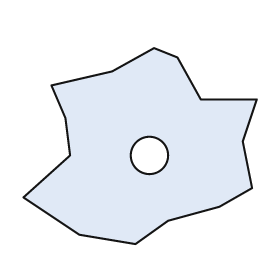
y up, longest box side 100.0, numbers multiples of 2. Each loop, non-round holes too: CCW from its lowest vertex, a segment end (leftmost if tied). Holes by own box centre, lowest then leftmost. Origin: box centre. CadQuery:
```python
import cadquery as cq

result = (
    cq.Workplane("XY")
    .moveTo(-2.0, -42.0)
    .lineTo(12.0, -32.0)
    .lineTo(34.0, -26.0)
    .lineTo(48.0, -18.0)
    .lineTo(44.0, 2.0)
    .lineTo(50.0, 20.0)
    .lineTo(26.0, 20.0)
    .lineTo(16.0, 38.0)
    .lineTo(6.0, 42.0)
    .lineTo(-12.0, 32.0)
    .lineTo(-38.0, 26.0)
    .lineTo(-32.0, 12.0)
    .lineTo(-30.0, -4.0)
    .lineTo(-50.0, -22.0)
    .lineTo(-26.0, -38.0)
    .close()
    .moveTo(4.0, -4.0)
    .circle(8.0)
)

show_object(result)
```